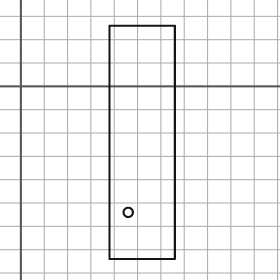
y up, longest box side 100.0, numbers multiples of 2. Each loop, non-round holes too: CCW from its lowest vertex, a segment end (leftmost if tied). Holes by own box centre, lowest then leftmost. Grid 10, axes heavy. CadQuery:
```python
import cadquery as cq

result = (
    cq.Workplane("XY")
    .moveTo(38.0, -74.0)
    .lineTo(66.0, -74.0)
    .lineTo(66.0, 26.0)
    .lineTo(38.0, 26.0)
    .close()
    .moveTo(46.0, -54.0)
    .circle(2.0)
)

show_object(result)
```